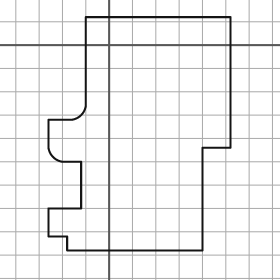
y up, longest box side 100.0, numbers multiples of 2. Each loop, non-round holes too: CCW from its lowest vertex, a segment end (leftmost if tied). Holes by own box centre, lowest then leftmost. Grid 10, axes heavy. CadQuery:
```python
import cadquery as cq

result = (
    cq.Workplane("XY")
    .moveTo(-18.0, -88.0)
    .lineTo(40.0, -88.0)
    .lineTo(40.0, -44.0)
    .lineTo(52.0, -44.0)
    .lineTo(52.0, 12.0)
    .lineTo(-10.0, 12.0)
    .lineTo(-10.0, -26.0)
    .threePointArc((-12.0, -30.0), (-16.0, -32.0))
    .lineTo(-26.0, -32.0)
    .lineTo(-26.0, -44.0)
    .threePointArc((-24.0, -48.0), (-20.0, -50.0))
    .lineTo(-12.0, -50.0)
    .lineTo(-12.0, -70.0)
    .lineTo(-26.0, -70.0)
    .lineTo(-26.0, -82.0)
    .lineTo(-18.0, -82.0)
    .close()
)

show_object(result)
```